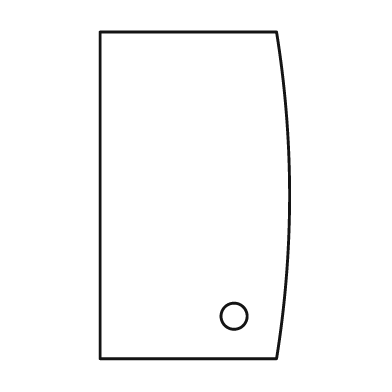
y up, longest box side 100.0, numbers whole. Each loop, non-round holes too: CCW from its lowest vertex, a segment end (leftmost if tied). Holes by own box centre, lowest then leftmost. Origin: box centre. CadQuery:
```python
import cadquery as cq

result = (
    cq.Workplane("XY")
    .moveTo(-29.0, -50.0)
    .lineTo(25.0, -50.0)
    .threePointArc((29.0, 0.0), (25.0, 50.0))
    .lineTo(-29.0, 50.0)
    .close()
    .moveTo(12.0, -37.0)
    .circle(4.0)
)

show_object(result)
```